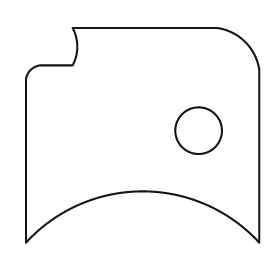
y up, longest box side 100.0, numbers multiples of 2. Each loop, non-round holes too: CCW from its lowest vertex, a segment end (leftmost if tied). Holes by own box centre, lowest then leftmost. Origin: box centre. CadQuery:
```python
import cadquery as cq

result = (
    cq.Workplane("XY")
    .moveTo(-50.0, -46.0)
    .threePointArc((0.0, -24.0), (50.0, -46.0))
    .lineTo(50.0, 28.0)
    .threePointArc((44.0, 40.0), (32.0, 46.0))
    .lineTo(-30.0, 46.0)
    .threePointArc((-28.0, 38.0), (-30.0, 30.0))
    .lineTo(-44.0, 30.0)
    .threePointArc((-48.0, 28.0), (-50.0, 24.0))
    .close()
    .moveTo(24.0, 2.0)
    .circle(10.0)
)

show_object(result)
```